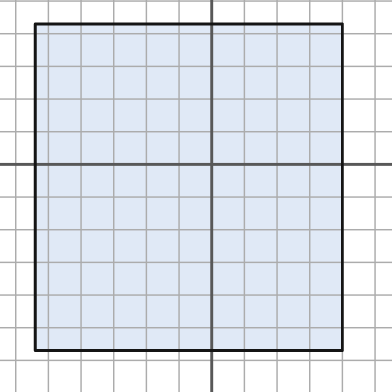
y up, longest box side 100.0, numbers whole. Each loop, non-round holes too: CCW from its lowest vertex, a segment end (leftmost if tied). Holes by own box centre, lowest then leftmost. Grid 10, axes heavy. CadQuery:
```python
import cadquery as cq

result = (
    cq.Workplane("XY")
    .moveTo(-54.0, -57.0)
    .lineTo(40.0, -57.0)
    .lineTo(40.0, 43.0)
    .lineTo(-54.0, 43.0)
    .close()
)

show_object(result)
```